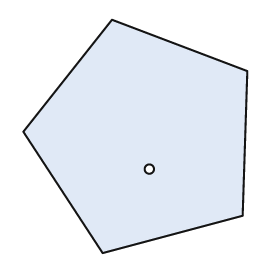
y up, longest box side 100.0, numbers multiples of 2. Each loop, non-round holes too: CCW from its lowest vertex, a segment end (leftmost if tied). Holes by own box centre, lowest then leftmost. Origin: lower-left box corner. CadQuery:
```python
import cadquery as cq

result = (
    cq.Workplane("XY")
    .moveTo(34.0, 0.0)
    .lineTo(94.0, 16.0)
    .lineTo(96.0, 78.0)
    .lineTo(38.0, 100.0)
    .lineTo(0.0, 52.0)
    .close()
    .moveTo(54.0, 36.0)
    .circle(2.0)
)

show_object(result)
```